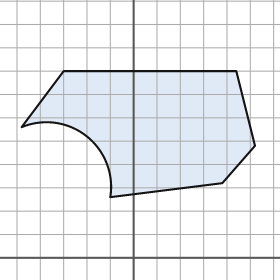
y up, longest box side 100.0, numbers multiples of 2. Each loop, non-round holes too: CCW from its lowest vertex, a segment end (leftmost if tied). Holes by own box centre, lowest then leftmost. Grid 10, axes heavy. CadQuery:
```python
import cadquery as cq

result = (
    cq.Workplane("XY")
    .moveTo(-10.0, 26.0)
    .lineTo(38.0, 32.0)
    .lineTo(52.0, 48.0)
    .lineTo(44.0, 80.0)
    .lineTo(-30.0, 80.0)
    .lineTo(-48.0, 56.0)
    .threePointArc((-20.0, 52.0), (-10.0, 26.0))
    .close()
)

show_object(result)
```